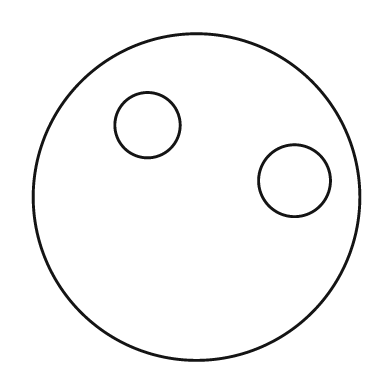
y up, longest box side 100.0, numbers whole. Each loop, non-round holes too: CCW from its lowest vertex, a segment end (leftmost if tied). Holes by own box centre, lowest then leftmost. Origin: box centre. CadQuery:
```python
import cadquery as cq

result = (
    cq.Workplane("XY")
    .moveTo(0.0, 0.0)
    .circle(50.0)
    .moveTo(30.0, 5.0)
    .circle(11.0)
    .moveTo(-15.0, 22.0)
    .circle(10.0)
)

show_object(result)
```